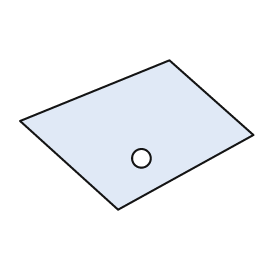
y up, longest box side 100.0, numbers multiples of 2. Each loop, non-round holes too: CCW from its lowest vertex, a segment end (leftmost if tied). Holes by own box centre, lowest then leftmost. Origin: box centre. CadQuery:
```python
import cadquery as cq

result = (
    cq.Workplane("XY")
    .moveTo(-8.0, -32.0)
    .lineTo(50.0, 0.0)
    .lineTo(14.0, 32.0)
    .lineTo(-50.0, 6.0)
    .close()
    .moveTo(2.0, -10.0)
    .circle(4.0)
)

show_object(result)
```